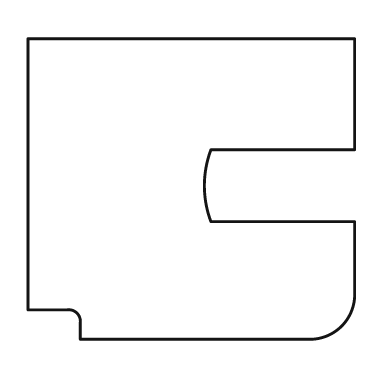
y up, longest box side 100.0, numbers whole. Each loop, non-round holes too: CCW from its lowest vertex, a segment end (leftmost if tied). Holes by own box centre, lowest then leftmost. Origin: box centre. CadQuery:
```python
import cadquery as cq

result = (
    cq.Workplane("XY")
    .moveTo(-34.0, -46.0)
    .lineTo(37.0, -46.0)
    .threePointArc((46.0, -42.0), (50.0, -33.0))
    .lineTo(50.0, -10.0)
    .lineTo(6.0, -10.0)
    .threePointArc((4.0, 1.0), (6.0, 12.0))
    .lineTo(50.0, 12.0)
    .lineTo(50.0, 46.0)
    .lineTo(-50.0, 46.0)
    .lineTo(-50.0, -37.0)
    .lineTo(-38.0, -37.0)
    .threePointArc((-35.0, -38.0), (-34.0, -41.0))
    .close()
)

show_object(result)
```